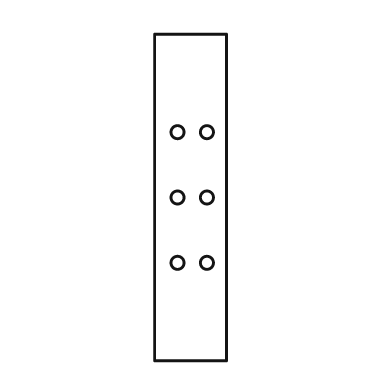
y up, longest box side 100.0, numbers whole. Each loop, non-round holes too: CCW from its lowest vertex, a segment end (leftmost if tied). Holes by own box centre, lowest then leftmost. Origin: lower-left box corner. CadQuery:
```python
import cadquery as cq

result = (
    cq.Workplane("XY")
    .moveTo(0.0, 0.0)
    .lineTo(22.0, 0.0)
    .lineTo(22.0, 100.0)
    .lineTo(0.0, 100.0)
    .close()
    .moveTo(7.0, 30.0)
    .circle(2.0)
    .moveTo(16.0, 30.0)
    .circle(2.0)
    .moveTo(7.0, 50.0)
    .circle(2.0)
    .moveTo(16.0, 50.0)
    .circle(2.0)
    .moveTo(7.0, 70.0)
    .circle(2.0)
    .moveTo(16.0, 70.0)
    .circle(2.0)
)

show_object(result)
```